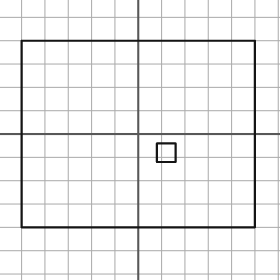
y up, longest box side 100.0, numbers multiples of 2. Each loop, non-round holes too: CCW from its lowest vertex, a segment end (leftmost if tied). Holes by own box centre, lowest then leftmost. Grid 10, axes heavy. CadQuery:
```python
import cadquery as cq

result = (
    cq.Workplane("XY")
    .moveTo(-50.0, -40.0)
    .lineTo(50.0, -40.0)
    .lineTo(50.0, 40.0)
    .lineTo(-50.0, 40.0)
    .close()
    .moveTo(8.0, -12.0)
    .lineTo(16.0, -12.0)
    .lineTo(16.0, -4.0)
    .lineTo(8.0, -4.0)
    .close()
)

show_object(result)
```